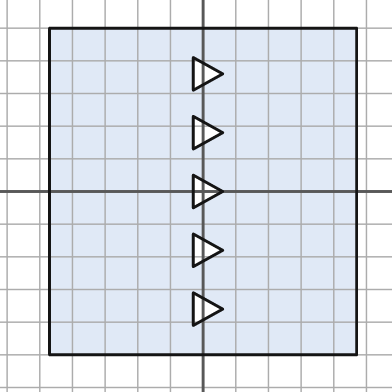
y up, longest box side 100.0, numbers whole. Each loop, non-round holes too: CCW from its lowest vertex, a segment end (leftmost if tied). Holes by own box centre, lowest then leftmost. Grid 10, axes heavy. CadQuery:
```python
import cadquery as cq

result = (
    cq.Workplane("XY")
    .moveTo(-47.0, -50.0)
    .lineTo(47.0, -50.0)
    .lineTo(47.0, 50.0)
    .lineTo(-47.0, 50.0)
    .close()
    .moveTo(-3.0, -41.0)
    .lineTo(6.0, -36.0)
    .lineTo(-3.0, -31.0)
    .close()
    .moveTo(-3.0, -23.0)
    .lineTo(6.0, -18.0)
    .lineTo(-3.0, -13.0)
    .close()
    .moveTo(-3.0, -5.0)
    .lineTo(6.0, 0.0)
    .lineTo(-3.0, 5.0)
    .close()
    .moveTo(-3.0, 13.0)
    .lineTo(6.0, 18.0)
    .lineTo(-3.0, 23.0)
    .close()
    .moveTo(-3.0, 31.0)
    .lineTo(6.0, 36.0)
    .lineTo(-3.0, 41.0)
    .close()
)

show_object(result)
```